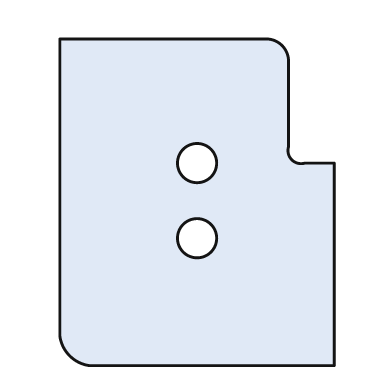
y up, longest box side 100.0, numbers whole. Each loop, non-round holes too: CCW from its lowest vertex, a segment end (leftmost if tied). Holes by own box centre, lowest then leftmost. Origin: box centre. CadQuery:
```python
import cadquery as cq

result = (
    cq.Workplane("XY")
    .moveTo(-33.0, -50.0)
    .lineTo(42.0, -50.0)
    .lineTo(42.0, 12.0)
    .lineTo(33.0, 12.0)
    .threePointArc((29.0, 13.0), (28.0, 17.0))
    .lineTo(28.0, 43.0)
    .threePointArc((26.0, 48.0), (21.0, 50.0))
    .lineTo(-42.0, 50.0)
    .lineTo(-42.0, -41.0)
    .threePointArc((-39.0, -47.0), (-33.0, -50.0))
    .close()
    .moveTo(0.0, -11.0)
    .circle(6.0)
    .moveTo(0.0, 12.0)
    .circle(6.0)
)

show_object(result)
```